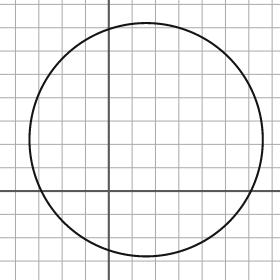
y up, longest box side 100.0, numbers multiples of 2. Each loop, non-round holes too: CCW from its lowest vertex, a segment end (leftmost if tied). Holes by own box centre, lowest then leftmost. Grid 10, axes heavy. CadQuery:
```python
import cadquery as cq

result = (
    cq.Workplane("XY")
    .moveTo(16.0, 22.0)
    .circle(50.0)
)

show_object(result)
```